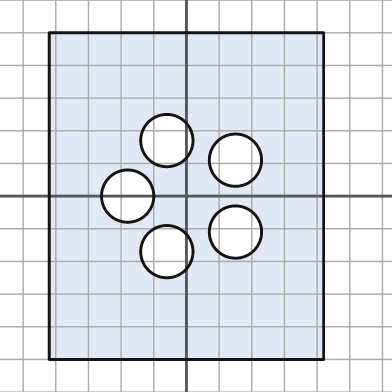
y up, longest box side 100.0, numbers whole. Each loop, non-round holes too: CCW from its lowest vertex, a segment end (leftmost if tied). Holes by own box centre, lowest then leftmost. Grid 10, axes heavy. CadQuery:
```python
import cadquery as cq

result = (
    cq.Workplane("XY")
    .moveTo(-42.0, -50.0)
    .lineTo(42.0, -50.0)
    .lineTo(42.0, 50.0)
    .lineTo(-42.0, 50.0)
    .close()
    .moveTo(-6.0, -17.0)
    .circle(8.0)
    .moveTo(15.0, -11.0)
    .circle(8.0)
    .moveTo(-18.0, 0.0)
    .circle(8.0)
    .moveTo(15.0, 11.0)
    .circle(8.0)
    .moveTo(-6.0, 17.0)
    .circle(8.0)
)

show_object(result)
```